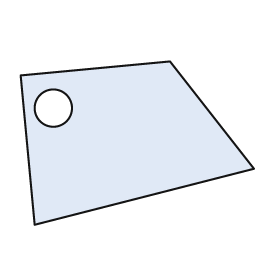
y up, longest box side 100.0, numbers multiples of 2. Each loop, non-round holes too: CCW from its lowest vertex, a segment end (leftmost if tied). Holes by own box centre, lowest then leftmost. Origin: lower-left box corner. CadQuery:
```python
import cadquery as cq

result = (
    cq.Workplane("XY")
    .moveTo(6.0, 0.0)
    .lineTo(100.0, 24.0)
    .lineTo(64.0, 70.0)
    .lineTo(0.0, 64.0)
    .close()
    .moveTo(14.0, 50.0)
    .circle(8.0)
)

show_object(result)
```